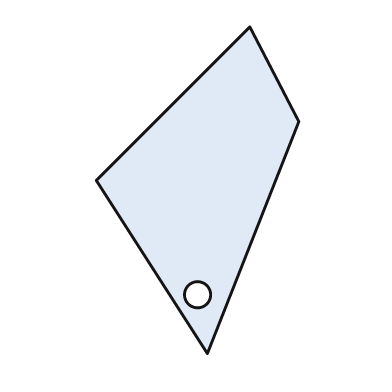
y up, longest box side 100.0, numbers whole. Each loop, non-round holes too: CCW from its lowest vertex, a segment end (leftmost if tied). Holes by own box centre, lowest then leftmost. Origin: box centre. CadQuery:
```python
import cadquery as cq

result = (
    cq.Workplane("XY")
    .moveTo(3.0, -50.0)
    .lineTo(31.0, 21.0)
    .lineTo(16.0, 50.0)
    .lineTo(-31.0, 3.0)
    .close()
    .moveTo(0.0, -32.0)
    .circle(4.0)
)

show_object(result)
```